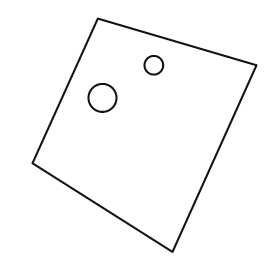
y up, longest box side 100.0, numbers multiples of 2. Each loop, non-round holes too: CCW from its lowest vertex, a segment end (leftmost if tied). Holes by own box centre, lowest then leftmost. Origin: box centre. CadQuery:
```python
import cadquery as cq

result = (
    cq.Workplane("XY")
    .moveTo(12.0, -50.0)
    .lineTo(48.0, 30.0)
    .lineTo(-20.0, 50.0)
    .lineTo(-48.0, -12.0)
    .close()
    .moveTo(-18.0, 16.0)
    .circle(6.0)
    .moveTo(4.0, 30.0)
    .circle(4.0)
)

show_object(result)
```